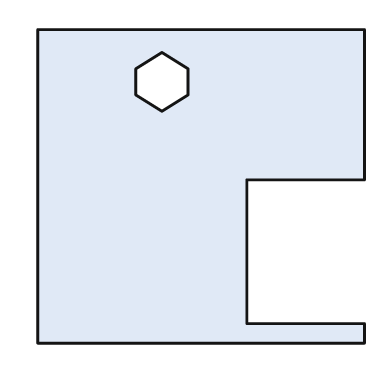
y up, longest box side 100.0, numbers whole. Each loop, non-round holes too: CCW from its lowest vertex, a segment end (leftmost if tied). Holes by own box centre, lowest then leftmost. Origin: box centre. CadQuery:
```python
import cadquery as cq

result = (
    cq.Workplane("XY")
    .moveTo(-50.0, -48.0)
    .lineTo(50.0, -48.0)
    .lineTo(50.0, -42.0)
    .lineTo(14.0, -42.0)
    .lineTo(14.0, 2.0)
    .lineTo(50.0, 2.0)
    .lineTo(50.0, 48.0)
    .lineTo(-50.0, 48.0)
    .close()
    .moveTo(-12.0, 23.0)
    .lineTo(-4.0, 28.0)
    .lineTo(-4.0, 36.0)
    .lineTo(-12.0, 41.0)
    .lineTo(-20.0, 36.0)
    .lineTo(-20.0, 28.0)
    .close()
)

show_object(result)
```